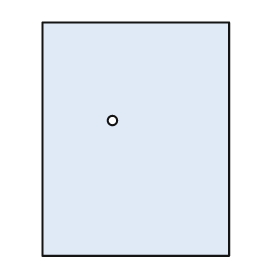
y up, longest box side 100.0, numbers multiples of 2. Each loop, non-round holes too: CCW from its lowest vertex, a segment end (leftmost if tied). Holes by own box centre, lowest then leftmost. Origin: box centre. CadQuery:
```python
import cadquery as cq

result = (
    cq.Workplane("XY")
    .moveTo(-40.0, -50.0)
    .lineTo(40.0, -50.0)
    .lineTo(40.0, 50.0)
    .lineTo(-40.0, 50.0)
    .close()
    .moveTo(-10.0, 8.0)
    .circle(2.0)
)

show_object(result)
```